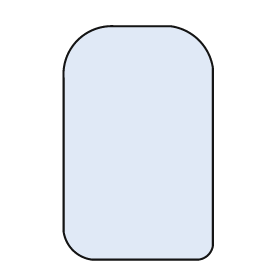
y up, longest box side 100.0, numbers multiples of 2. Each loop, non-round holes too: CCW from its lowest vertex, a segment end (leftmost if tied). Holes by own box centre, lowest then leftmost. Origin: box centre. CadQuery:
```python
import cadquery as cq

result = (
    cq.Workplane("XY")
    .moveTo(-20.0, -50.0)
    .lineTo(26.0, -50.0)
    .threePointArc((30.0, -48.0), (32.0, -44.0))
    .lineTo(32.0, 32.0)
    .threePointArc((26.0, 44.0), (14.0, 50.0))
    .lineTo(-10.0, 50.0)
    .threePointArc((-26.0, 44.0), (-32.0, 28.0))
    .lineTo(-32.0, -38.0)
    .threePointArc((-28.0, -46.0), (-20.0, -50.0))
    .close()
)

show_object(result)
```